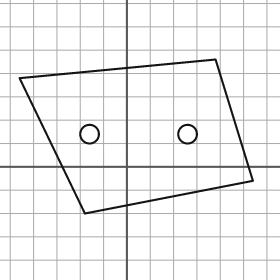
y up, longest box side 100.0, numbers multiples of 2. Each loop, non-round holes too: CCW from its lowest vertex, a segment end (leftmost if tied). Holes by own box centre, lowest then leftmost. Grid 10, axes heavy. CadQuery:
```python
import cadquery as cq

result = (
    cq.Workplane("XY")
    .moveTo(-18.0, -20.0)
    .lineTo(54.0, -6.0)
    .lineTo(38.0, 46.0)
    .lineTo(-46.0, 38.0)
    .close()
    .moveTo(-16.0, 14.0)
    .circle(4.0)
    .moveTo(26.0, 14.0)
    .circle(4.0)
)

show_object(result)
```